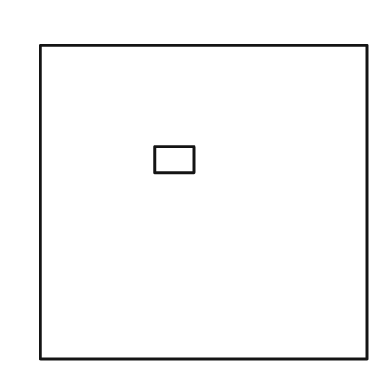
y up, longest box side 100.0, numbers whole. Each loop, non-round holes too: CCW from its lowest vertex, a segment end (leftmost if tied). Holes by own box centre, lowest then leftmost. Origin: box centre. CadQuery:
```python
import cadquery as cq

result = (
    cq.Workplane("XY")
    .moveTo(-50.0, -48.0)
    .lineTo(50.0, -48.0)
    .lineTo(50.0, 48.0)
    .lineTo(-50.0, 48.0)
    .close()
    .moveTo(-15.0, 9.0)
    .lineTo(-3.0, 9.0)
    .lineTo(-3.0, 17.0)
    .lineTo(-15.0, 17.0)
    .close()
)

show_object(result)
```